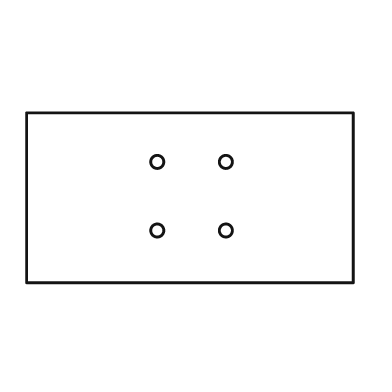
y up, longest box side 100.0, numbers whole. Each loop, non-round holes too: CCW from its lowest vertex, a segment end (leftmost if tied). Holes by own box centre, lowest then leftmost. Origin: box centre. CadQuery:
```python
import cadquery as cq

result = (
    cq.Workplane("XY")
    .moveTo(-50.0, -26.0)
    .lineTo(50.0, -26.0)
    .lineTo(50.0, 26.0)
    .lineTo(-50.0, 26.0)
    .close()
    .moveTo(-10.0, -10.0)
    .circle(2.0)
    .moveTo(11.0, -10.0)
    .circle(2.0)
    .moveTo(-10.0, 11.0)
    .circle(2.0)
    .moveTo(11.0, 11.0)
    .circle(2.0)
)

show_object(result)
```